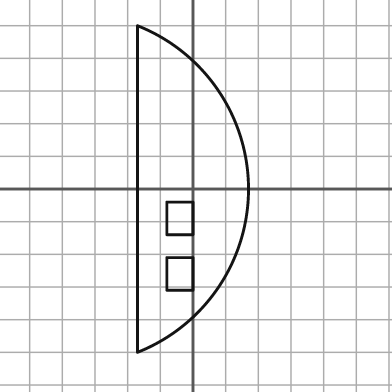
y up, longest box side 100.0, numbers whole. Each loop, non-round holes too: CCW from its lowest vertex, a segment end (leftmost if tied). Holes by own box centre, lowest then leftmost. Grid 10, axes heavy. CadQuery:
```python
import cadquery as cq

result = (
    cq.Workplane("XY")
    .moveTo(-17.0, -50.0)
    .threePointArc((17.0, 0.0), (-17.0, 50.0))
    .close()
    .moveTo(-8.0, -31.0)
    .lineTo(0.0, -31.0)
    .lineTo(0.0, -21.0)
    .lineTo(-8.0, -21.0)
    .close()
    .moveTo(-8.0, -14.0)
    .lineTo(0.0, -14.0)
    .lineTo(0.0, -4.0)
    .lineTo(-8.0, -4.0)
    .close()
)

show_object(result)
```